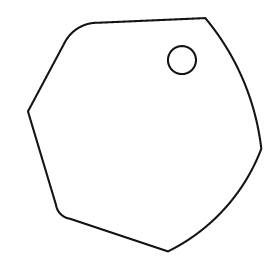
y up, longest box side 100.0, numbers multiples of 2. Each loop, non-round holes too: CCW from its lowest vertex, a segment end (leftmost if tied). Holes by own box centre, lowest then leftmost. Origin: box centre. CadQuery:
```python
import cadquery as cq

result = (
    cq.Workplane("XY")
    .moveTo(10.0, -50.0)
    .threePointArc((34.0, -32.0), (50.0, -6.0))
    .threePointArc((42.0, 24.0), (26.0, 50.0))
    .lineTo(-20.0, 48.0)
    .threePointArc((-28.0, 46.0), (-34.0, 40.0))
    .lineTo(-50.0, 10.0)
    .lineTo(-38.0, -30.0)
    .threePointArc((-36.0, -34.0), (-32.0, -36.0))
    .close()
    .moveTo(16.0, 32.0)
    .circle(6.0)
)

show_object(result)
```